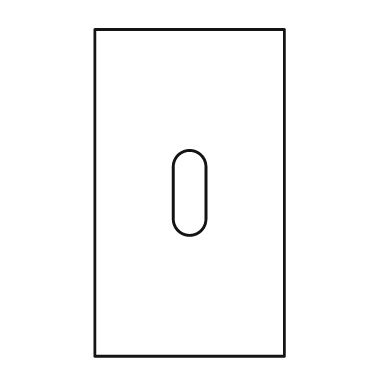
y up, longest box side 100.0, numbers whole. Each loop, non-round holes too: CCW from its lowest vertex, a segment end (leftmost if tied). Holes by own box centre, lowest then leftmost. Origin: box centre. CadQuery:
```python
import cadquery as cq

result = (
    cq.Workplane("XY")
    .moveTo(-29.0, -50.0)
    .lineTo(29.0, -50.0)
    .lineTo(29.0, 50.0)
    .lineTo(-29.0, 50.0)
    .close()
    .moveTo(-5.0, -8.0)
    .threePointArc((0.0, -13.0), (5.0, -8.0))
    .lineTo(5.0, 8.0)
    .threePointArc((0.0, 13.0), (-5.0, 8.0))
    .close()
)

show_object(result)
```